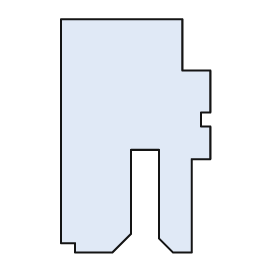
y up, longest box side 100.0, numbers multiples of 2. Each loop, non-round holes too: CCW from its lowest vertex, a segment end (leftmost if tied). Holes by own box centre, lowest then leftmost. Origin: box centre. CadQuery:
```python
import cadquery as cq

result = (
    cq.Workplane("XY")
    .moveTo(-26.0, -50.0)
    .lineTo(-10.0, -50.0)
    .lineTo(-2.0, -42.0)
    .lineTo(-2.0, -6.0)
    .lineTo(10.0, -6.0)
    .lineTo(10.0, -44.0)
    .lineTo(16.0, -50.0)
    .lineTo(24.0, -50.0)
    .lineTo(24.0, -10.0)
    .lineTo(32.0, -10.0)
    .lineTo(32.0, 4.0)
    .lineTo(28.0, 4.0)
    .lineTo(28.0, 10.0)
    .lineTo(32.0, 10.0)
    .lineTo(32.0, 28.0)
    .lineTo(20.0, 28.0)
    .lineTo(20.0, 50.0)
    .lineTo(-32.0, 50.0)
    .lineTo(-32.0, -46.0)
    .lineTo(-26.0, -46.0)
    .close()
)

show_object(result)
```